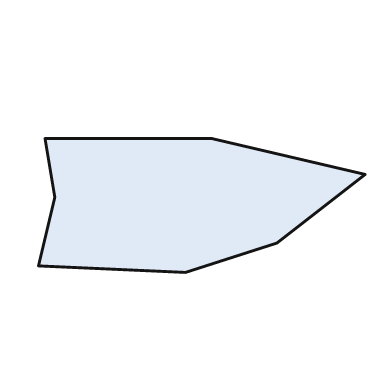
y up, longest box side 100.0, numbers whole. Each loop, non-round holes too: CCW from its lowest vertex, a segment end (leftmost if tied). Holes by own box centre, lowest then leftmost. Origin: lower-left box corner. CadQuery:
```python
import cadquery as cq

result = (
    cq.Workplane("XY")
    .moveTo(45.0, 0.0)
    .lineTo(73.0, 9.0)
    .lineTo(100.0, 30.0)
    .lineTo(53.0, 41.0)
    .lineTo(2.0, 41.0)
    .lineTo(5.0, 23.0)
    .lineTo(0.0, 2.0)
    .close()
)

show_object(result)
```